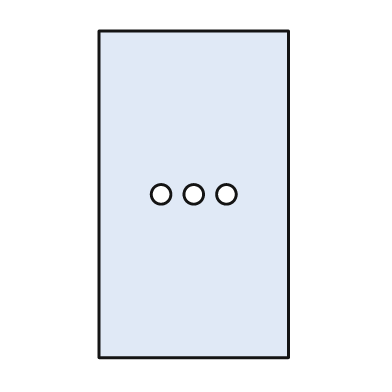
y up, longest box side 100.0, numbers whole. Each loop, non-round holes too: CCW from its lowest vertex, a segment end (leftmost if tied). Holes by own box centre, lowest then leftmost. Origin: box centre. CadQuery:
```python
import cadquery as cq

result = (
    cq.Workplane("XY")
    .moveTo(-29.0, -50.0)
    .lineTo(29.0, -50.0)
    .lineTo(29.0, 50.0)
    .lineTo(-29.0, 50.0)
    .close()
    .moveTo(-10.0, 0.0)
    .circle(3.0)
    .moveTo(0.0, 0.0)
    .circle(3.0)
    .moveTo(10.0, 0.0)
    .circle(3.0)
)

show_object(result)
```